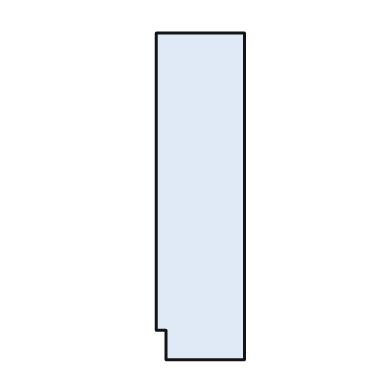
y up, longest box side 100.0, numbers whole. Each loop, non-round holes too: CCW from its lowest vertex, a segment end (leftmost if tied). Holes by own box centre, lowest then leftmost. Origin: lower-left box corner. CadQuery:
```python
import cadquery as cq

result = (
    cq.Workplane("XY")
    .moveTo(3.0, 0.0)
    .lineTo(27.0, 0.0)
    .lineTo(27.0, 100.0)
    .lineTo(0.0, 100.0)
    .lineTo(0.0, 9.0)
    .lineTo(3.0, 9.0)
    .close()
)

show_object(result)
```